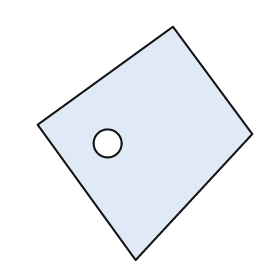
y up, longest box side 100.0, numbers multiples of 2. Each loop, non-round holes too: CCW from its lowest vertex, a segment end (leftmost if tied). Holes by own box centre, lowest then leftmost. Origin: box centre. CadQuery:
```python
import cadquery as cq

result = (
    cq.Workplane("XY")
    .moveTo(-4.0, -50.0)
    .lineTo(46.0, 4.0)
    .lineTo(12.0, 50.0)
    .lineTo(-46.0, 8.0)
    .close()
    .moveTo(-16.0, 0.0)
    .circle(6.0)
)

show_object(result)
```